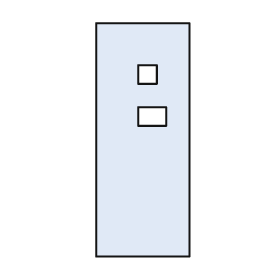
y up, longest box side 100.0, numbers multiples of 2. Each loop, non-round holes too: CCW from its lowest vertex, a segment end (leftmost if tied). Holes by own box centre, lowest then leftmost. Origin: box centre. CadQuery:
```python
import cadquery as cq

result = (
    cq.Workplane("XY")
    .moveTo(-20.0, -50.0)
    .lineTo(20.0, -50.0)
    .lineTo(20.0, 50.0)
    .lineTo(-20.0, 50.0)
    .close()
    .moveTo(-2.0, 6.0)
    .lineTo(10.0, 6.0)
    .lineTo(10.0, 14.0)
    .lineTo(-2.0, 14.0)
    .close()
    .moveTo(-2.0, 24.0)
    .lineTo(6.0, 24.0)
    .lineTo(6.0, 32.0)
    .lineTo(-2.0, 32.0)
    .close()
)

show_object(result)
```